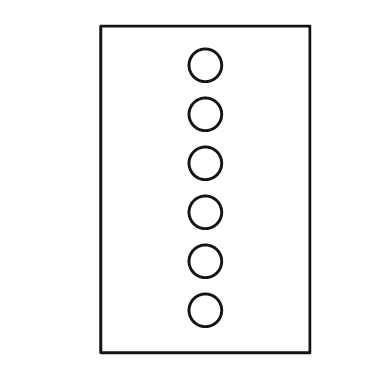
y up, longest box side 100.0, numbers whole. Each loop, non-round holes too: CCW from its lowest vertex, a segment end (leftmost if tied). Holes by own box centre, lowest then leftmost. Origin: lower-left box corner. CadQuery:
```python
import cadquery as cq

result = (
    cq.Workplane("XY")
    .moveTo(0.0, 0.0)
    .lineTo(64.0, 0.0)
    .lineTo(64.0, 100.0)
    .lineTo(0.0, 100.0)
    .close()
    .moveTo(32.0, 13.0)
    .circle(5.0)
    .moveTo(32.0, 28.0)
    .circle(5.0)
    .moveTo(32.0, 43.0)
    .circle(5.0)
    .moveTo(32.0, 58.0)
    .circle(5.0)
    .moveTo(32.0, 73.0)
    .circle(5.0)
    .moveTo(32.0, 88.0)
    .circle(5.0)
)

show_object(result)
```